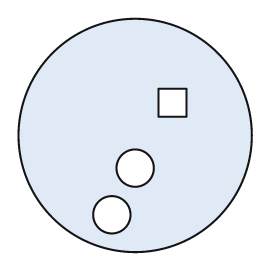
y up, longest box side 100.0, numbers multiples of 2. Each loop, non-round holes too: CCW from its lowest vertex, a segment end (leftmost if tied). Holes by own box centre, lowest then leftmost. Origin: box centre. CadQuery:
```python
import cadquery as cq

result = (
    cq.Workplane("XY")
    .moveTo(0.0, 0.0)
    .circle(50.0)
    .moveTo(-10.0, -34.0)
    .circle(8.0)
    .moveTo(0.0, -14.0)
    .circle(8.0)
    .moveTo(10.0, 8.0)
    .lineTo(22.0, 8.0)
    .lineTo(22.0, 20.0)
    .lineTo(10.0, 20.0)
    .close()
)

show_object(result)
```